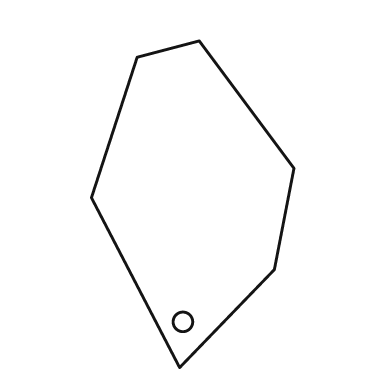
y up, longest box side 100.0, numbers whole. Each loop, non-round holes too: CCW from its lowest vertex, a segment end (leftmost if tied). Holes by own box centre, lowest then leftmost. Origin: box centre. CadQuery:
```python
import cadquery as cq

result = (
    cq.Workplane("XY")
    .moveTo(-4.0, -50.0)
    .lineTo(25.0, -20.0)
    .lineTo(31.0, 11.0)
    .lineTo(2.0, 50.0)
    .lineTo(-17.0, 45.0)
    .lineTo(-31.0, 2.0)
    .close()
    .moveTo(-3.0, -36.0)
    .circle(3.0)
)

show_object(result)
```